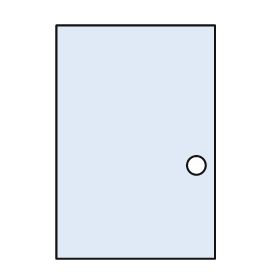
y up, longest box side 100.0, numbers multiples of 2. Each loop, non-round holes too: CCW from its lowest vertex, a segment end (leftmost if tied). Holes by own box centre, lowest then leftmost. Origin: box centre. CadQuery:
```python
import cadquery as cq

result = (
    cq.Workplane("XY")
    .moveTo(-34.0, -50.0)
    .lineTo(34.0, -50.0)
    .lineTo(34.0, 50.0)
    .lineTo(-34.0, 50.0)
    .close()
    .moveTo(26.0, -10.0)
    .circle(4.0)
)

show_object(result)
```